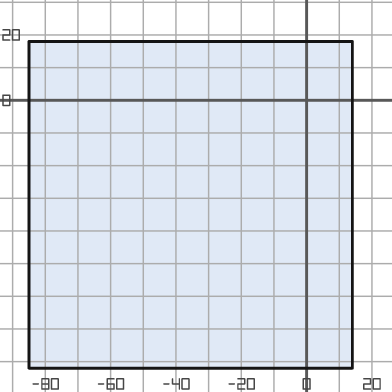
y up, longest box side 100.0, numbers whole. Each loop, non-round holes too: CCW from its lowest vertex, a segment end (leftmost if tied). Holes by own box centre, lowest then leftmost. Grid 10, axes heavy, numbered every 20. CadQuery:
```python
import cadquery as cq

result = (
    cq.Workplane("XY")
    .moveTo(-85.0, -82.0)
    .lineTo(14.0, -82.0)
    .lineTo(14.0, 18.0)
    .lineTo(-85.0, 18.0)
    .close()
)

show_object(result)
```